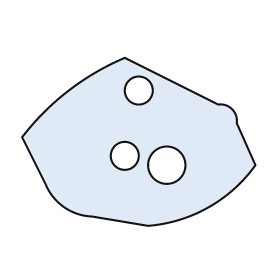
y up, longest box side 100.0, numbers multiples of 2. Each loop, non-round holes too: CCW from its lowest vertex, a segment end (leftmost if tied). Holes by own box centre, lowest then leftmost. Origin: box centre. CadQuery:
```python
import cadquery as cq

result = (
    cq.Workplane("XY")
    .moveTo(4.0, -36.0)
    .threePointArc((30.0, -28.0), (50.0, -10.0))
    .lineTo(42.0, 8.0)
    .threePointArc((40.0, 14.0), (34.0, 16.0))
    .lineTo(-6.0, 36.0)
    .threePointArc((-30.0, 22.0), (-50.0, 2.0))
    .lineTo(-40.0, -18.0)
    .threePointArc((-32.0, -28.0), (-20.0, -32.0))
    .close()
    .moveTo(12.0, -10.0)
    .circle(8.0)
    .moveTo(-6.0, -6.0)
    .circle(6.0)
    .moveTo(0.0, 22.0)
    .circle(6.0)
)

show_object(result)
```